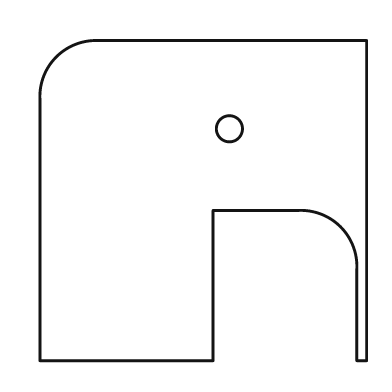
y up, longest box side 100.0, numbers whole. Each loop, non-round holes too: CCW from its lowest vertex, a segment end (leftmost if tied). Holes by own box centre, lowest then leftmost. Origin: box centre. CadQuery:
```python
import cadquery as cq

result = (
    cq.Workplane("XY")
    .moveTo(-50.0, -49.0)
    .lineTo(3.0, -49.0)
    .lineTo(3.0, -3.0)
    .lineTo(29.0, -3.0)
    .threePointArc((42.0, -8.0), (47.0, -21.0))
    .lineTo(47.0, -49.0)
    .lineTo(50.0, -49.0)
    .lineTo(50.0, 49.0)
    .lineTo(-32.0, 49.0)
    .threePointArc((-45.0, 44.0), (-50.0, 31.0))
    .close()
    .moveTo(8.0, 22.0)
    .circle(4.0)
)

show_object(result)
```